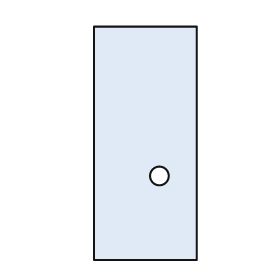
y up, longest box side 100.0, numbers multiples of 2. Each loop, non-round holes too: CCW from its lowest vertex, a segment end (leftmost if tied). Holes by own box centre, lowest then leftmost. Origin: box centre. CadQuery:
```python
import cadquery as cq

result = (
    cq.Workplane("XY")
    .moveTo(-22.0, -50.0)
    .lineTo(22.0, -50.0)
    .lineTo(22.0, 50.0)
    .lineTo(-22.0, 50.0)
    .close()
    .moveTo(6.0, -14.0)
    .circle(4.0)
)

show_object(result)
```